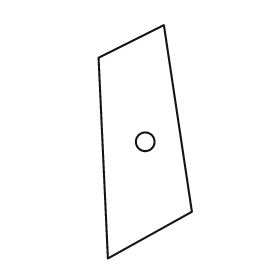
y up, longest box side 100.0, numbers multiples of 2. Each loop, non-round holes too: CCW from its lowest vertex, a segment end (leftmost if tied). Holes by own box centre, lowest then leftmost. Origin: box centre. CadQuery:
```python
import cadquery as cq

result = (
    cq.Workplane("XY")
    .moveTo(-16.0, -50.0)
    .lineTo(20.0, -30.0)
    .lineTo(8.0, 50.0)
    .lineTo(-20.0, 36.0)
    .close()
    .moveTo(0.0, 0.0)
    .circle(4.0)
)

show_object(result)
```